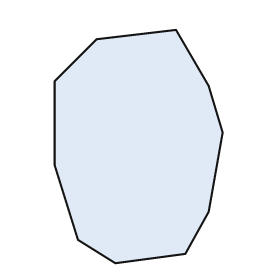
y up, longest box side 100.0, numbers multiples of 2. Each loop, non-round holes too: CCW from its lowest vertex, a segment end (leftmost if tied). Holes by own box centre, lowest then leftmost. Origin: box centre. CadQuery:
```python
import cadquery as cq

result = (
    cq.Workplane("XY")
    .moveTo(-10.0, -50.0)
    .lineTo(20.0, -46.0)
    .lineTo(30.0, -28.0)
    .lineTo(36.0, 6.0)
    .lineTo(30.0, 26.0)
    .lineTo(16.0, 50.0)
    .lineTo(-18.0, 46.0)
    .lineTo(-36.0, 28.0)
    .lineTo(-36.0, -8.0)
    .lineTo(-26.0, -40.0)
    .close()
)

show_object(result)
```